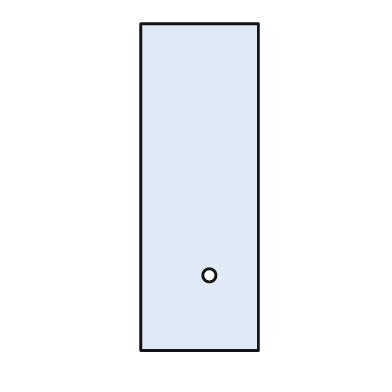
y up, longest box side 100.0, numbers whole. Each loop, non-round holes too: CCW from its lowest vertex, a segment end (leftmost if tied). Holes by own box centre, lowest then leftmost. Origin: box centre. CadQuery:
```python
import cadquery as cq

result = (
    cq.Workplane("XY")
    .moveTo(-18.0, -50.0)
    .lineTo(18.0, -50.0)
    .lineTo(18.0, 50.0)
    .lineTo(-18.0, 50.0)
    .close()
    .moveTo(3.0, -27.0)
    .circle(2.0)
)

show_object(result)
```